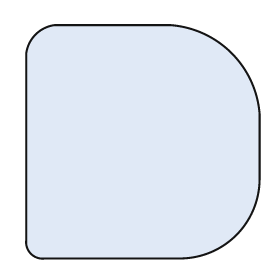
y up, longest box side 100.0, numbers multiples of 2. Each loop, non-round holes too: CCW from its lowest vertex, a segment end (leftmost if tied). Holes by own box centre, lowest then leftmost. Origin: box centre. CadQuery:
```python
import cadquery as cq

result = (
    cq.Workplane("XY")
    .moveTo(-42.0, -50.0)
    .lineTo(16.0, -50.0)
    .threePointArc((40.0, -40.0), (50.0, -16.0))
    .lineTo(50.0, 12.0)
    .threePointArc((38.0, 38.0), (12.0, 50.0))
    .lineTo(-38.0, 50.0)
    .threePointArc((-46.0, 46.0), (-50.0, 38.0))
    .lineTo(-50.0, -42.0)
    .threePointArc((-48.0, -48.0), (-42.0, -50.0))
    .close()
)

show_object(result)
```